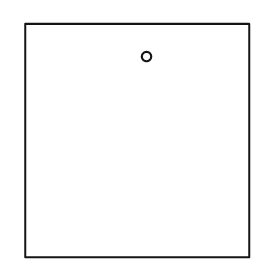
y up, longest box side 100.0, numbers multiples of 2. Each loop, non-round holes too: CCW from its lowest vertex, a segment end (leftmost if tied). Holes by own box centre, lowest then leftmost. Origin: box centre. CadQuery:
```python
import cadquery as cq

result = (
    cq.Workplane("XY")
    .moveTo(-48.0, -50.0)
    .lineTo(48.0, -50.0)
    .lineTo(48.0, 50.0)
    .lineTo(-48.0, 50.0)
    .close()
    .moveTo(4.0, 36.0)
    .circle(2.0)
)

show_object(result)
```